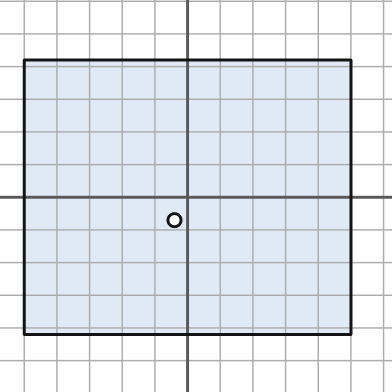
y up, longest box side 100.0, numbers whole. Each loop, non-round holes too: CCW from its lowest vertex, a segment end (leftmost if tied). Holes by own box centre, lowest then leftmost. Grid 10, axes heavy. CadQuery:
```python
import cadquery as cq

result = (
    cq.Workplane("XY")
    .moveTo(-50.0, -42.0)
    .lineTo(50.0, -42.0)
    .lineTo(50.0, 42.0)
    .lineTo(-50.0, 42.0)
    .close()
    .moveTo(-4.0, -7.0)
    .circle(2.0)
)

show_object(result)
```